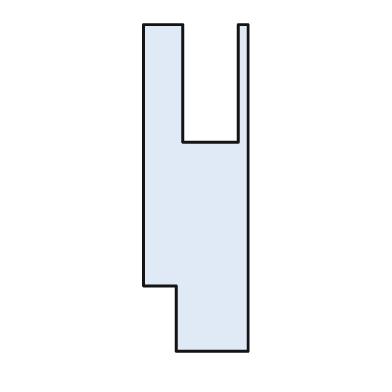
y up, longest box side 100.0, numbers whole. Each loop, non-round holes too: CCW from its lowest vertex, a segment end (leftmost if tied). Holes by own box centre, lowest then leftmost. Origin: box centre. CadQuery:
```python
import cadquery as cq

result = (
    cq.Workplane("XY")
    .moveTo(-6.0, -50.0)
    .lineTo(16.0, -50.0)
    .lineTo(16.0, 50.0)
    .lineTo(13.0, 50.0)
    .lineTo(13.0, 14.0)
    .lineTo(-4.0, 14.0)
    .lineTo(-4.0, 50.0)
    .lineTo(-16.0, 50.0)
    .lineTo(-16.0, -30.0)
    .lineTo(-6.0, -30.0)
    .close()
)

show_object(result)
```